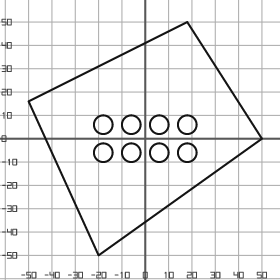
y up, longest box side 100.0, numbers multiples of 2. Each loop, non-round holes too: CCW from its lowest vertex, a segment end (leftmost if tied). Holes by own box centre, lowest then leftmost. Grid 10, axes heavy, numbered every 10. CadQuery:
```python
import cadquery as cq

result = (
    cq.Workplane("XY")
    .moveTo(-20.0, -50.0)
    .lineTo(50.0, 0.0)
    .lineTo(18.0, 50.0)
    .lineTo(-50.0, 16.0)
    .close()
    .moveTo(-18.0, -6.0)
    .circle(4.0)
    .moveTo(-6.0, -6.0)
    .circle(4.0)
    .moveTo(6.0, -6.0)
    .circle(4.0)
    .moveTo(18.0, -6.0)
    .circle(4.0)
    .moveTo(-18.0, 6.0)
    .circle(4.0)
    .moveTo(-6.0, 6.0)
    .circle(4.0)
    .moveTo(6.0, 6.0)
    .circle(4.0)
    .moveTo(18.0, 6.0)
    .circle(4.0)
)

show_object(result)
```